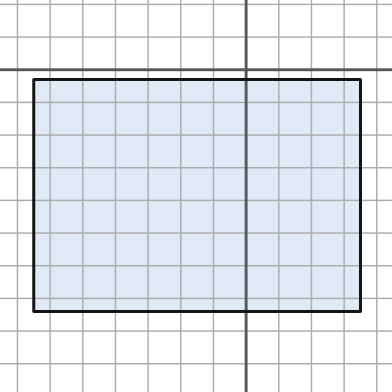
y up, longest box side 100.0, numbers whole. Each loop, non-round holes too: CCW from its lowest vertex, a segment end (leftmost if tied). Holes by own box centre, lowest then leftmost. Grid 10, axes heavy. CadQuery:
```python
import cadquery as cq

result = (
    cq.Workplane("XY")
    .moveTo(-65.0, -74.0)
    .lineTo(35.0, -74.0)
    .lineTo(35.0, -3.0)
    .lineTo(-65.0, -3.0)
    .close()
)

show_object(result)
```